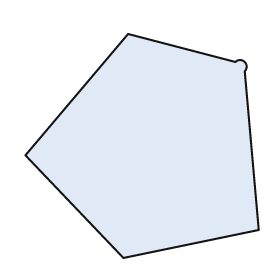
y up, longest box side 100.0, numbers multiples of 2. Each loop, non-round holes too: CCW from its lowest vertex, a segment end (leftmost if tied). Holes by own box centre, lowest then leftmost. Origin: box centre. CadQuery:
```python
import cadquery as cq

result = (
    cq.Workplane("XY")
    .moveTo(-8.0, -48.0)
    .lineTo(50.0, -36.0)
    .lineTo(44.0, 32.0)
    .threePointArc((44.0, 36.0), (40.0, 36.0))
    .lineTo(-6.0, 48.0)
    .lineTo(-50.0, -4.0)
    .close()
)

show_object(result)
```